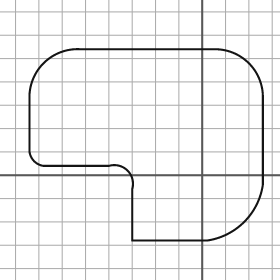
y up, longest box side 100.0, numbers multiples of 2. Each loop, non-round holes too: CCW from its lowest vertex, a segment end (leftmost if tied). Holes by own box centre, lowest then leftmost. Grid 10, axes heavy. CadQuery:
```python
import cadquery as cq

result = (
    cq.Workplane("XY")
    .moveTo(-30.0, -28.0)
    .lineTo(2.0, -28.0)
    .threePointArc((18.0, -20.0), (26.0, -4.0))
    .lineTo(26.0, 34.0)
    .threePointArc((20.0, 48.0), (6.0, 54.0))
    .lineTo(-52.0, 54.0)
    .threePointArc((-68.0, 48.0), (-74.0, 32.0))
    .lineTo(-74.0, 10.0)
    .threePointArc((-72.0, 6.0), (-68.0, 4.0))
    .lineTo(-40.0, 4.0)
    .threePointArc((-32.0, 2.0), (-30.0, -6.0))
    .close()
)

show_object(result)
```